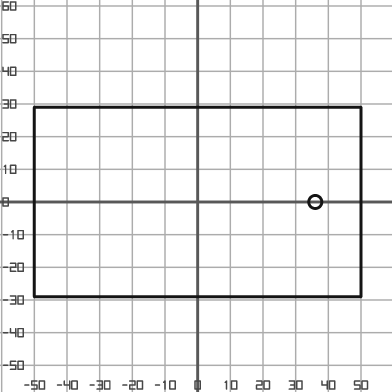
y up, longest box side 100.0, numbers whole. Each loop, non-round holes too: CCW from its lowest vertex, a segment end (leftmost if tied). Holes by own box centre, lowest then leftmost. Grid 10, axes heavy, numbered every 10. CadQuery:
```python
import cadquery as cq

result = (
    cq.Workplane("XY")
    .moveTo(-50.0, -29.0)
    .lineTo(50.0, -29.0)
    .lineTo(50.0, 29.0)
    .lineTo(-50.0, 29.0)
    .close()
    .moveTo(36.0, 0.0)
    .circle(2.0)
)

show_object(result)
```